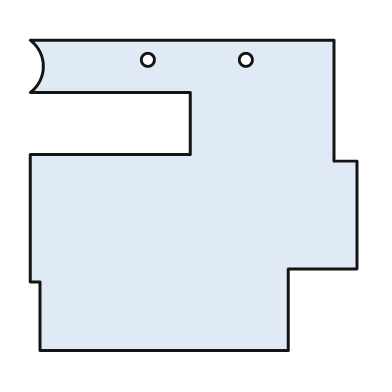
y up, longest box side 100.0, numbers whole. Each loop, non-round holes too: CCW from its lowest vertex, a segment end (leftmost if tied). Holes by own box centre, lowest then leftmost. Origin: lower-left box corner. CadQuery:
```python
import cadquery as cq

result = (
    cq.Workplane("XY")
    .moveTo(3.0, 0.0)
    .lineTo(79.0, 0.0)
    .lineTo(79.0, 25.0)
    .lineTo(100.0, 25.0)
    .lineTo(100.0, 58.0)
    .lineTo(93.0, 58.0)
    .lineTo(93.0, 95.0)
    .lineTo(0.0, 95.0)
    .threePointArc((4.0, 87.0), (0.0, 79.0))
    .lineTo(49.0, 79.0)
    .lineTo(49.0, 60.0)
    .lineTo(0.0, 60.0)
    .lineTo(0.0, 21.0)
    .lineTo(3.0, 21.0)
    .close()
    .moveTo(36.0, 89.0)
    .circle(2.0)
    .moveTo(66.0, 89.0)
    .circle(2.0)
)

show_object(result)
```